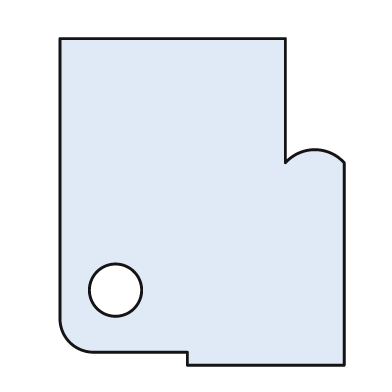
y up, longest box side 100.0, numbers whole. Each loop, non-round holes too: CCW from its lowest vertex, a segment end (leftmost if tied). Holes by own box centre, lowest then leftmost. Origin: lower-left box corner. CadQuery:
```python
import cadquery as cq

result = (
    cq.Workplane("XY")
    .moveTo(39.0, 0.0)
    .lineTo(87.0, 0.0)
    .lineTo(87.0, 62.0)
    .threePointArc((78.0, 66.0), (69.0, 62.0))
    .lineTo(69.0, 100.0)
    .lineTo(0.0, 100.0)
    .lineTo(0.0, 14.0)
    .threePointArc((3.0, 7.0), (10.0, 4.0))
    .lineTo(39.0, 4.0)
    .close()
    .moveTo(17.0, 23.0)
    .circle(8.0)
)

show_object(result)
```